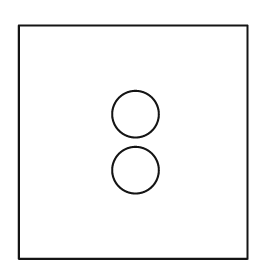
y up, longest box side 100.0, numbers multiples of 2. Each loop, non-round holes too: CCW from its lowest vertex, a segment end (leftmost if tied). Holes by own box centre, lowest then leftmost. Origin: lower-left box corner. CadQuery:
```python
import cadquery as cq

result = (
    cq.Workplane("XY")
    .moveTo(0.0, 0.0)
    .lineTo(98.0, 0.0)
    .lineTo(98.0, 100.0)
    .lineTo(0.0, 100.0)
    .close()
    .moveTo(50.0, 38.0)
    .circle(10.0)
    .moveTo(50.0, 62.0)
    .circle(10.0)
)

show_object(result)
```